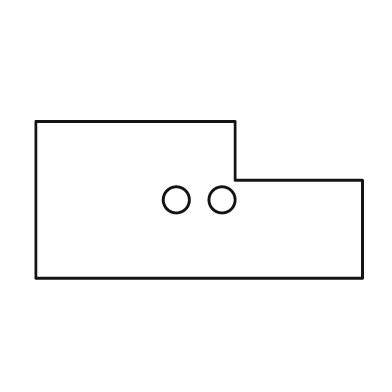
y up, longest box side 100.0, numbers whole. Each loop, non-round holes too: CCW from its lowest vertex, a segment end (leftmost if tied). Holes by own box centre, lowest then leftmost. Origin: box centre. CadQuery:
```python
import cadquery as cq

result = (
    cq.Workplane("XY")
    .moveTo(-50.0, -24.0)
    .lineTo(50.0, -24.0)
    .lineTo(50.0, 6.0)
    .lineTo(11.0, 6.0)
    .lineTo(11.0, 24.0)
    .lineTo(-50.0, 24.0)
    .close()
    .moveTo(-7.0, 0.0)
    .circle(4.0)
    .moveTo(7.0, 0.0)
    .circle(4.0)
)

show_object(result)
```